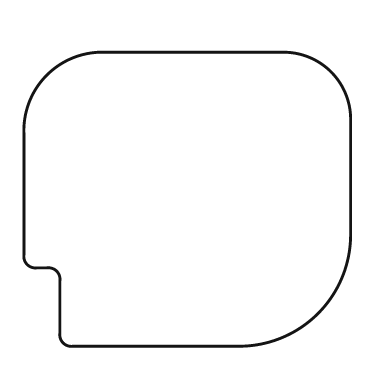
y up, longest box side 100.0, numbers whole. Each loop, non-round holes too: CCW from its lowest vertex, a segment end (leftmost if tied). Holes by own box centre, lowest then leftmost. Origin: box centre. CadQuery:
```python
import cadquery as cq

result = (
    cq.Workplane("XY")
    .moveTo(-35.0, -45.0)
    .lineTo(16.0, -45.0)
    .threePointArc((40.0, -35.0), (50.0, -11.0))
    .lineTo(50.0, 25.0)
    .threePointArc((44.0, 39.0), (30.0, 45.0))
    .lineTo(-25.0, 45.0)
    .threePointArc((-43.0, 38.0), (-50.0, 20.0))
    .lineTo(-50.0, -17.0)
    .threePointArc((-49.0, -20.0), (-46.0, -21.0))
    .lineTo(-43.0, -21.0)
    .threePointArc((-40.0, -22.0), (-39.0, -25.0))
    .lineTo(-39.0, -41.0)
    .threePointArc((-38.0, -44.0), (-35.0, -45.0))
    .close()
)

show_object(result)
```